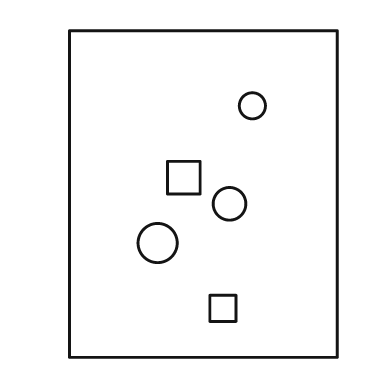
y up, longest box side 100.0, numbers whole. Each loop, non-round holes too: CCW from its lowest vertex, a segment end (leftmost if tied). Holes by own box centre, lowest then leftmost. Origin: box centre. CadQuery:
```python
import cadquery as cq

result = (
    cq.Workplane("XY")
    .moveTo(-41.0, -50.0)
    .lineTo(41.0, -50.0)
    .lineTo(41.0, 50.0)
    .lineTo(-41.0, 50.0)
    .close()
    .moveTo(2.0, -39.0)
    .lineTo(10.0, -39.0)
    .lineTo(10.0, -31.0)
    .lineTo(2.0, -31.0)
    .close()
    .moveTo(-14.0, -15.0)
    .circle(6.0)
    .moveTo(8.0, -3.0)
    .circle(5.0)
    .moveTo(-11.0, 0.0)
    .lineTo(-1.0, 0.0)
    .lineTo(-1.0, 10.0)
    .lineTo(-11.0, 10.0)
    .close()
    .moveTo(15.0, 27.0)
    .circle(4.0)
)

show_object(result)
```